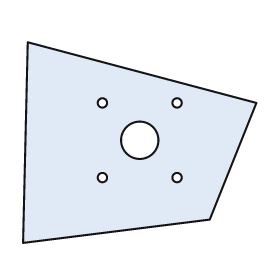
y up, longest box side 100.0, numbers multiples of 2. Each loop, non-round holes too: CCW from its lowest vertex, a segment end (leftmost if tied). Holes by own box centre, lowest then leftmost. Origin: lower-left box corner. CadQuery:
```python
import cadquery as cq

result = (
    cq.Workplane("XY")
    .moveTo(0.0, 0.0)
    .lineTo(80.0, 10.0)
    .lineTo(100.0, 60.0)
    .lineTo(2.0, 86.0)
    .close()
    .moveTo(34.0, 28.0)
    .circle(2.0)
    .moveTo(66.0, 28.0)
    .circle(2.0)
    .moveTo(50.0, 44.0)
    .circle(8.0)
    .moveTo(34.0, 60.0)
    .circle(2.0)
    .moveTo(66.0, 60.0)
    .circle(2.0)
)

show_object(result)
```